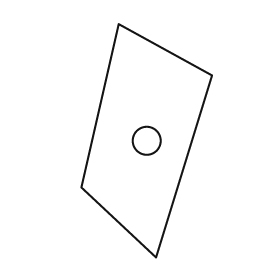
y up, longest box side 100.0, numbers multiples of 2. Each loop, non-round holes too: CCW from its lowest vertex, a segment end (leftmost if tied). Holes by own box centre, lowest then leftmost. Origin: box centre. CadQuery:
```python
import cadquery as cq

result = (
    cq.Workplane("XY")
    .moveTo(4.0, -50.0)
    .lineTo(28.0, 28.0)
    .lineTo(-12.0, 50.0)
    .lineTo(-28.0, -20.0)
    .close()
    .moveTo(0.0, 0.0)
    .circle(6.0)
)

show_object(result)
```